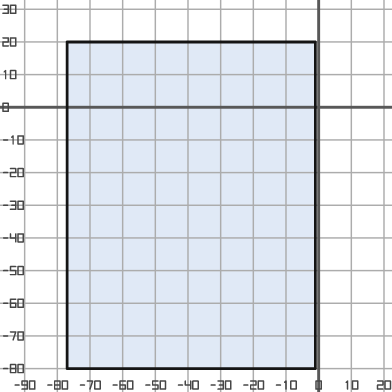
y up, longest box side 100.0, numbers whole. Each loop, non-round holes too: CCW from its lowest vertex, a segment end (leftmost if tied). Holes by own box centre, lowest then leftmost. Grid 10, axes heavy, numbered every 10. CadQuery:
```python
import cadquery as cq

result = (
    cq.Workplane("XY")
    .moveTo(-77.0, -80.0)
    .lineTo(-1.0, -80.0)
    .lineTo(-1.0, 20.0)
    .lineTo(-77.0, 20.0)
    .close()
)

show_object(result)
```